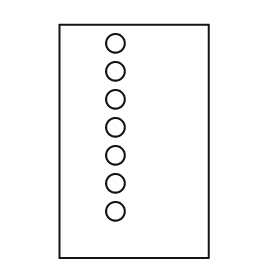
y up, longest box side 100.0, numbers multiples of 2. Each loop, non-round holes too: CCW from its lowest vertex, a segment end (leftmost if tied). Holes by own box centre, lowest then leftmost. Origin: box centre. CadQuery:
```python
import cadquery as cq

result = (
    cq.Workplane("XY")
    .moveTo(-32.0, -50.0)
    .lineTo(32.0, -50.0)
    .lineTo(32.0, 50.0)
    .lineTo(-32.0, 50.0)
    .close()
    .moveTo(-8.0, -30.0)
    .circle(4.0)
    .moveTo(-8.0, -18.0)
    .circle(4.0)
    .moveTo(-8.0, -6.0)
    .circle(4.0)
    .moveTo(-8.0, 6.0)
    .circle(4.0)
    .moveTo(-8.0, 18.0)
    .circle(4.0)
    .moveTo(-8.0, 30.0)
    .circle(4.0)
    .moveTo(-8.0, 42.0)
    .circle(4.0)
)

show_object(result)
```